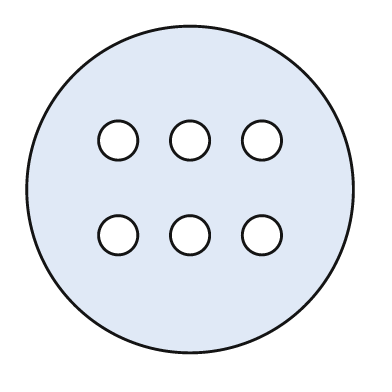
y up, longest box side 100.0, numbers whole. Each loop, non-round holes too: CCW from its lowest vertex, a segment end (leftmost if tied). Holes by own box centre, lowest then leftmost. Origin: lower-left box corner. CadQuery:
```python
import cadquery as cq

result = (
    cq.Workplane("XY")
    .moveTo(50.0, 50.0)
    .circle(50.0)
    .moveTo(28.0, 36.0)
    .circle(6.0)
    .moveTo(50.0, 36.0)
    .circle(6.0)
    .moveTo(72.0, 36.0)
    .circle(6.0)
    .moveTo(28.0, 65.0)
    .circle(6.0)
    .moveTo(50.0, 65.0)
    .circle(6.0)
    .moveTo(72.0, 65.0)
    .circle(6.0)
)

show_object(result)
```